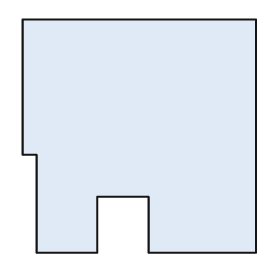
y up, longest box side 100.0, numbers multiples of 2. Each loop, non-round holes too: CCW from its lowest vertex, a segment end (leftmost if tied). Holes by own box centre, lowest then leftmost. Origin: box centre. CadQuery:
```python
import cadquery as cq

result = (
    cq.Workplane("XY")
    .moveTo(-44.0, -50.0)
    .lineTo(-18.0, -50.0)
    .lineTo(-18.0, -26.0)
    .lineTo(4.0, -26.0)
    .lineTo(4.0, -50.0)
    .lineTo(50.0, -50.0)
    .lineTo(50.0, 50.0)
    .lineTo(-50.0, 50.0)
    .lineTo(-50.0, -8.0)
    .lineTo(-44.0, -8.0)
    .close()
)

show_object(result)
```